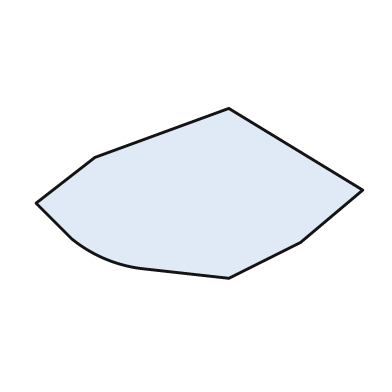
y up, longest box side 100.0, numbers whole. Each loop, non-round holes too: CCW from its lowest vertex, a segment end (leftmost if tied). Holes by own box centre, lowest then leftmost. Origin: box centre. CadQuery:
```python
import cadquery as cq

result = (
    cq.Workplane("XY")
    .moveTo(9.0, -26.0)
    .lineTo(31.0, -15.0)
    .lineTo(50.0, 1.0)
    .lineTo(9.0, 26.0)
    .lineTo(-32.0, 11.0)
    .lineTo(-50.0, -3.0)
    .lineTo(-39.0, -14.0)
    .threePointArc((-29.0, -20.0), (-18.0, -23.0))
    .close()
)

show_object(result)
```